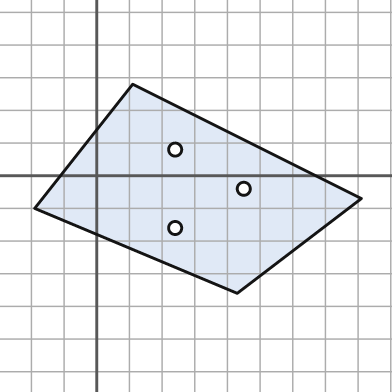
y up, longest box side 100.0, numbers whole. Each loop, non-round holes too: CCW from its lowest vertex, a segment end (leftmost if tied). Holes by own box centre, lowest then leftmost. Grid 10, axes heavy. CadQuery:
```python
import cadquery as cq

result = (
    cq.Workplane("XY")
    .moveTo(43.0, -36.0)
    .lineTo(81.0, -7.0)
    .lineTo(11.0, 28.0)
    .lineTo(-19.0, -10.0)
    .close()
    .moveTo(24.0, -16.0)
    .circle(2.0)
    .moveTo(45.0, -4.0)
    .circle(2.0)
    .moveTo(24.0, 8.0)
    .circle(2.0)
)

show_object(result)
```